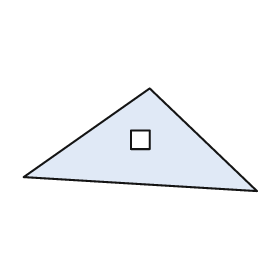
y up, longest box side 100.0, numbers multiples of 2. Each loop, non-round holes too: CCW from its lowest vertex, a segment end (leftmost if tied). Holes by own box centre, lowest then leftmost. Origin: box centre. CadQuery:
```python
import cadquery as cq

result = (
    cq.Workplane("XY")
    .moveTo(50.0, -22.0)
    .lineTo(4.0, 22.0)
    .lineTo(-50.0, -16.0)
    .close()
    .moveTo(-4.0, -4.0)
    .lineTo(4.0, -4.0)
    .lineTo(4.0, 4.0)
    .lineTo(-4.0, 4.0)
    .close()
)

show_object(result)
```